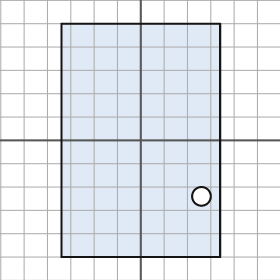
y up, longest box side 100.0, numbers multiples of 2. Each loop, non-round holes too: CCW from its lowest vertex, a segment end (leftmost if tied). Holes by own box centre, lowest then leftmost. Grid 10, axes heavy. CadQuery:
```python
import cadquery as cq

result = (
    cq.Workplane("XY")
    .moveTo(-34.0, -50.0)
    .lineTo(34.0, -50.0)
    .lineTo(34.0, 50.0)
    .lineTo(-34.0, 50.0)
    .close()
    .moveTo(26.0, -24.0)
    .circle(4.0)
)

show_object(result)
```